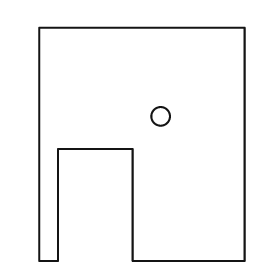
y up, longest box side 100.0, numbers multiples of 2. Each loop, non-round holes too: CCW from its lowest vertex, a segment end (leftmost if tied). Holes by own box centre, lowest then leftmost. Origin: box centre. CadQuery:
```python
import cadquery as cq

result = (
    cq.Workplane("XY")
    .moveTo(-44.0, -50.0)
    .lineTo(-36.0, -50.0)
    .lineTo(-36.0, -2.0)
    .lineTo(-4.0, -2.0)
    .lineTo(-4.0, -50.0)
    .lineTo(44.0, -50.0)
    .lineTo(44.0, 50.0)
    .lineTo(-44.0, 50.0)
    .close()
    .moveTo(8.0, 12.0)
    .circle(4.0)
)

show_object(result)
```